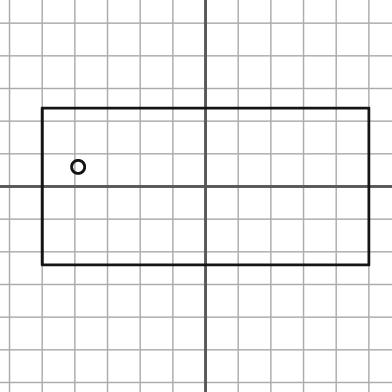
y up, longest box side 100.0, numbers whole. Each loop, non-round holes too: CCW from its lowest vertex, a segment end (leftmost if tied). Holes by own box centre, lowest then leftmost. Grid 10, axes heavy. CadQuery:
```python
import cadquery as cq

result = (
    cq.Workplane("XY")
    .moveTo(-50.0, -24.0)
    .lineTo(50.0, -24.0)
    .lineTo(50.0, 24.0)
    .lineTo(-50.0, 24.0)
    .close()
    .moveTo(-39.0, 6.0)
    .circle(2.0)
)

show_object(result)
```